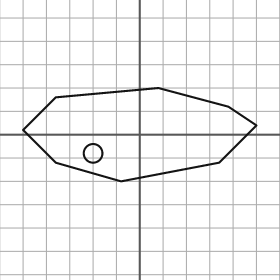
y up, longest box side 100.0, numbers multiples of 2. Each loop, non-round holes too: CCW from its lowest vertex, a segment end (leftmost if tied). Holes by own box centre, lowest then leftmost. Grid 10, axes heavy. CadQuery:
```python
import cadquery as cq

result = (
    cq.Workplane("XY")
    .moveTo(-8.0, -20.0)
    .lineTo(34.0, -12.0)
    .lineTo(50.0, 4.0)
    .lineTo(38.0, 12.0)
    .lineTo(8.0, 20.0)
    .lineTo(-36.0, 16.0)
    .lineTo(-50.0, 2.0)
    .lineTo(-36.0, -12.0)
    .close()
    .moveTo(-20.0, -8.0)
    .circle(4.0)
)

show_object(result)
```